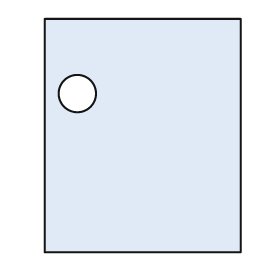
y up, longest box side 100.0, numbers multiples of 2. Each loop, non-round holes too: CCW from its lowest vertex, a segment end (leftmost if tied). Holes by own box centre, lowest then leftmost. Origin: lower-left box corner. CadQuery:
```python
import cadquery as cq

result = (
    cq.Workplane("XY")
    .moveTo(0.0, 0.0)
    .lineTo(84.0, 0.0)
    .lineTo(84.0, 100.0)
    .lineTo(0.0, 100.0)
    .close()
    .moveTo(14.0, 68.0)
    .circle(8.0)
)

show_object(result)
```